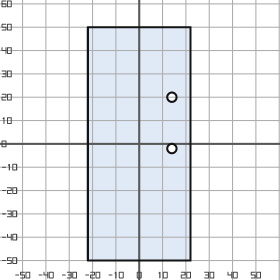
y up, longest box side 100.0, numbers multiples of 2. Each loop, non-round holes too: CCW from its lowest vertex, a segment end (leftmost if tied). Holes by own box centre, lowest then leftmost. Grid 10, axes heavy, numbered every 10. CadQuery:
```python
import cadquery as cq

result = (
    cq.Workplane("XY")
    .moveTo(-22.0, -50.0)
    .lineTo(22.0, -50.0)
    .lineTo(22.0, 50.0)
    .lineTo(-22.0, 50.0)
    .close()
    .moveTo(14.0, -2.0)
    .circle(2.0)
    .moveTo(14.0, 20.0)
    .circle(2.0)
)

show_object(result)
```